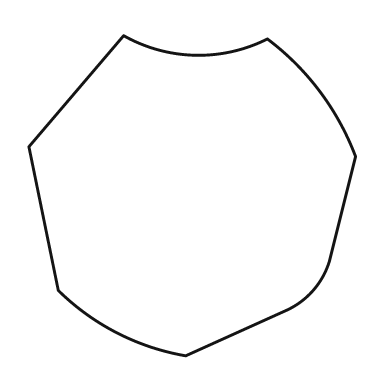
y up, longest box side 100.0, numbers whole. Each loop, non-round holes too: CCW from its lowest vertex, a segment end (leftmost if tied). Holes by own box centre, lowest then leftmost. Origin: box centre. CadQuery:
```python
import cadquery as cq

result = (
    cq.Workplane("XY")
    .moveTo(-2.0, -49.0)
    .lineTo(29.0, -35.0)
    .threePointArc((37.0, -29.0), (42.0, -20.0))
    .lineTo(50.0, 12.0)
    .threePointArc((39.0, 32.0), (23.0, 48.0))
    .threePointArc((1.0, 43.0), (-21.0, 49.0))
    .lineTo(-50.0, 15.0)
    .lineTo(-41.0, -29.0)
    .threePointArc((-23.0, -42.0), (-2.0, -49.0))
    .close()
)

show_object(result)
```